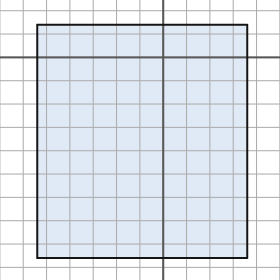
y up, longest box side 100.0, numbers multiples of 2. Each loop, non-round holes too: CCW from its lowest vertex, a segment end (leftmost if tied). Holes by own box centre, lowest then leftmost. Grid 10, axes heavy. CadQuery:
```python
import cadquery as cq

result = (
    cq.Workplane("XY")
    .moveTo(-54.0, -86.0)
    .lineTo(36.0, -86.0)
    .lineTo(36.0, 14.0)
    .lineTo(-54.0, 14.0)
    .close()
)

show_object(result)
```